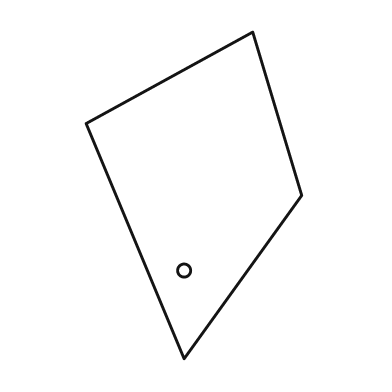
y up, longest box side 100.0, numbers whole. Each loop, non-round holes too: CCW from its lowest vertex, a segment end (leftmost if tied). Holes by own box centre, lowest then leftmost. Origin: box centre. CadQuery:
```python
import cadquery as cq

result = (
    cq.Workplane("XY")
    .moveTo(-3.0, -50.0)
    .lineTo(33.0, 0.0)
    .lineTo(18.0, 50.0)
    .lineTo(-33.0, 22.0)
    .close()
    .moveTo(-3.0, -23.0)
    .circle(2.0)
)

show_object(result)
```